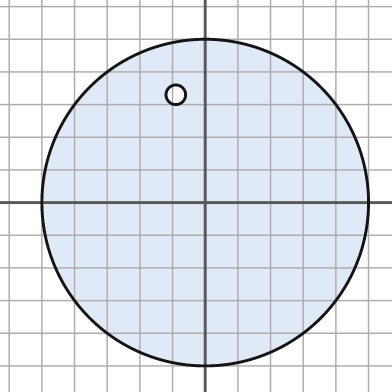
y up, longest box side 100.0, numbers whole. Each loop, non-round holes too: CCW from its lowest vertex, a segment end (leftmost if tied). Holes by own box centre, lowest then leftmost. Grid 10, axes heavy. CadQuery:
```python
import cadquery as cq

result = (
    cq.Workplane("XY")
    .moveTo(0.0, 0.0)
    .circle(50.0)
    .moveTo(-9.0, 33.0)
    .circle(3.0)
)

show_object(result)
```